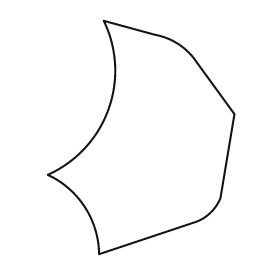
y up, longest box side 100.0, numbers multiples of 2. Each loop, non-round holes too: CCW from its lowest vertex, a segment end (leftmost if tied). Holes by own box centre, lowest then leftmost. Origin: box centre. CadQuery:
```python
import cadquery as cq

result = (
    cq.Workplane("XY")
    .moveTo(-18.0, -50.0)
    .lineTo(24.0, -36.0)
    .threePointArc((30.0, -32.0), (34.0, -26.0))
    .lineTo(40.0, 10.0)
    .lineTo(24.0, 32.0)
    .threePointArc((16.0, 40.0), (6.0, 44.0))
    .lineTo(-16.0, 50.0)
    .threePointArc((-14.0, 12.0), (-40.0, -16.0))
    .threePointArc((-24.0, -30.0), (-18.0, -50.0))
    .close()
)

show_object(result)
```